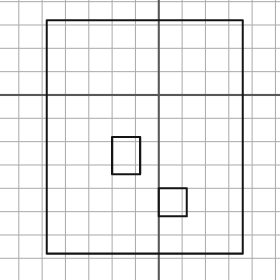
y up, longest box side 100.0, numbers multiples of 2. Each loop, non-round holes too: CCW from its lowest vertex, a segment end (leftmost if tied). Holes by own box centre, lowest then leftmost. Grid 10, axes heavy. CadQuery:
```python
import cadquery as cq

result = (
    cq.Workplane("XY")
    .moveTo(-48.0, -68.0)
    .lineTo(36.0, -68.0)
    .lineTo(36.0, 32.0)
    .lineTo(-48.0, 32.0)
    .close()
    .moveTo(0.0, -52.0)
    .lineTo(12.0, -52.0)
    .lineTo(12.0, -40.0)
    .lineTo(0.0, -40.0)
    .close()
    .moveTo(-20.0, -34.0)
    .lineTo(-8.0, -34.0)
    .lineTo(-8.0, -18.0)
    .lineTo(-20.0, -18.0)
    .close()
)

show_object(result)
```